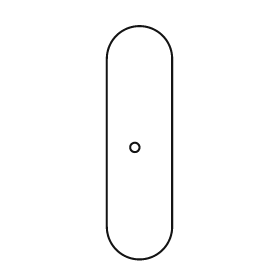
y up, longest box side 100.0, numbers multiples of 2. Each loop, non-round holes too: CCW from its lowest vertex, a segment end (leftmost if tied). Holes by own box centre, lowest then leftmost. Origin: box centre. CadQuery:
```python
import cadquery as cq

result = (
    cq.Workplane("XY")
    .moveTo(-14.0, -36.0)
    .threePointArc((0.0, -50.0), (14.0, -36.0))
    .lineTo(14.0, 36.0)
    .threePointArc((0.0, 50.0), (-14.0, 36.0))
    .close()
    .moveTo(-2.0, -2.0)
    .circle(2.0)
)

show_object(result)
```